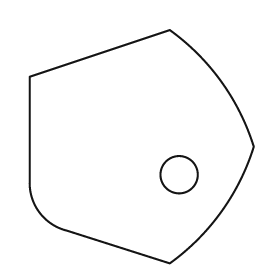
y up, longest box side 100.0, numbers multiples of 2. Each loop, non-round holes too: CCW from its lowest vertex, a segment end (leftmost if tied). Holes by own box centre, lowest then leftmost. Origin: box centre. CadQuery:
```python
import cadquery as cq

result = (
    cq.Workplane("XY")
    .moveTo(12.0, -50.0)
    .threePointArc((34.0, -28.0), (48.0, 0.0))
    .threePointArc((34.0, 28.0), (12.0, 50.0))
    .lineTo(-48.0, 30.0)
    .lineTo(-48.0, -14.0)
    .threePointArc((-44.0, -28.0), (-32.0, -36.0))
    .close()
    .moveTo(16.0, -12.0)
    .circle(8.0)
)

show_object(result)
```